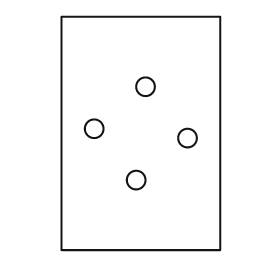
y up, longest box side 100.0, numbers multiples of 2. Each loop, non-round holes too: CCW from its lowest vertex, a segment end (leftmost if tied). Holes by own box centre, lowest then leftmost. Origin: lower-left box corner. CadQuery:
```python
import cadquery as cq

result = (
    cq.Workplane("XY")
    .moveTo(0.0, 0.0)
    .lineTo(68.0, 0.0)
    .lineTo(68.0, 100.0)
    .lineTo(0.0, 100.0)
    .close()
    .moveTo(32.0, 30.0)
    .circle(4.0)
    .moveTo(54.0, 48.0)
    .circle(4.0)
    .moveTo(14.0, 52.0)
    .circle(4.0)
    .moveTo(36.0, 70.0)
    .circle(4.0)
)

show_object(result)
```